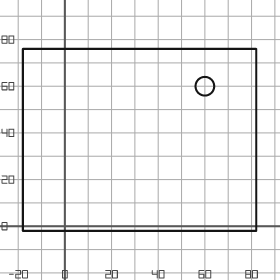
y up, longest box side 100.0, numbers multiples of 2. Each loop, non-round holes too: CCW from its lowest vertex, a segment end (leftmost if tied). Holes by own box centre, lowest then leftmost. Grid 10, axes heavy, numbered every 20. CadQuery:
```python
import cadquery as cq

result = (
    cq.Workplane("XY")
    .moveTo(-18.0, -2.0)
    .lineTo(82.0, -2.0)
    .lineTo(82.0, 76.0)
    .lineTo(-18.0, 76.0)
    .close()
    .moveTo(60.0, 60.0)
    .circle(4.0)
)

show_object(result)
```